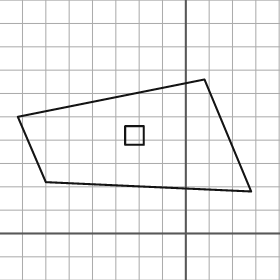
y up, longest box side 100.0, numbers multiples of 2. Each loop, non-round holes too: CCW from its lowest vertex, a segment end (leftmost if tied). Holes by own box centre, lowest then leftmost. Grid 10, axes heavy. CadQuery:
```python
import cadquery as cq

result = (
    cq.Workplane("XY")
    .moveTo(28.0, 18.0)
    .lineTo(8.0, 66.0)
    .lineTo(-72.0, 50.0)
    .lineTo(-60.0, 22.0)
    .close()
    .moveTo(-26.0, 38.0)
    .lineTo(-18.0, 38.0)
    .lineTo(-18.0, 46.0)
    .lineTo(-26.0, 46.0)
    .close()
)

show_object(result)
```